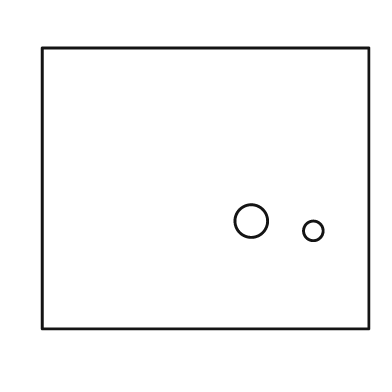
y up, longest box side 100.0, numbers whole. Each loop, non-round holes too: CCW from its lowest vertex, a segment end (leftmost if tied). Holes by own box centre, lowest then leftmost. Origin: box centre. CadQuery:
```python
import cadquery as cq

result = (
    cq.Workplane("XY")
    .moveTo(-50.0, -43.0)
    .lineTo(50.0, -43.0)
    .lineTo(50.0, 43.0)
    .lineTo(-50.0, 43.0)
    .close()
    .moveTo(33.0, -13.0)
    .circle(3.0)
    .moveTo(14.0, -10.0)
    .circle(5.0)
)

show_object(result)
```